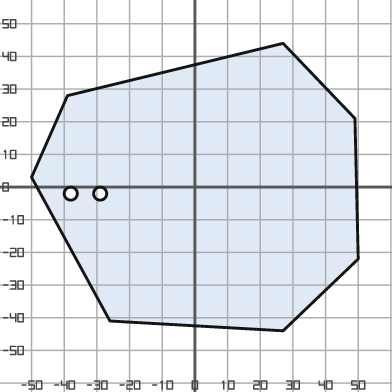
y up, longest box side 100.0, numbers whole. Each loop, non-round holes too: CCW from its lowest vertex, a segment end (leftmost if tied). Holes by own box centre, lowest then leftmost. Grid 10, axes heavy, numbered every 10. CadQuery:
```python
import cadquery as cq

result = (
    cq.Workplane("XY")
    .moveTo(27.0, -44.0)
    .lineTo(50.0, -22.0)
    .lineTo(49.0, 21.0)
    .lineTo(27.0, 44.0)
    .lineTo(-39.0, 28.0)
    .lineTo(-50.0, 3.0)
    .lineTo(-26.0, -41.0)
    .close()
    .moveTo(-38.0, -2.0)
    .circle(2.0)
    .moveTo(-29.0, -2.0)
    .circle(2.0)
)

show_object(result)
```